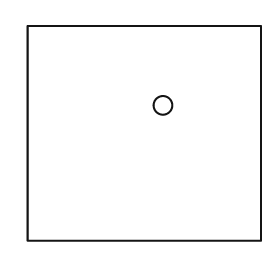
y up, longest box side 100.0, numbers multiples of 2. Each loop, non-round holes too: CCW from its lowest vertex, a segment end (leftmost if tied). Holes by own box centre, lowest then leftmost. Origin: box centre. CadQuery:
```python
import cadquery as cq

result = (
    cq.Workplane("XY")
    .moveTo(-50.0, -46.0)
    .lineTo(50.0, -46.0)
    .lineTo(50.0, 46.0)
    .lineTo(-50.0, 46.0)
    .close()
    .moveTo(8.0, 12.0)
    .circle(4.0)
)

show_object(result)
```